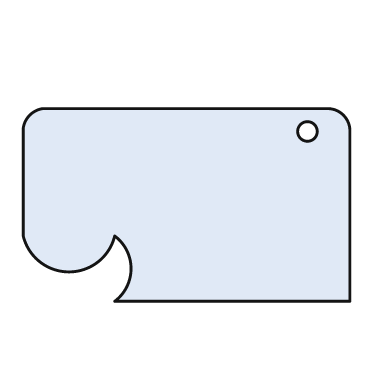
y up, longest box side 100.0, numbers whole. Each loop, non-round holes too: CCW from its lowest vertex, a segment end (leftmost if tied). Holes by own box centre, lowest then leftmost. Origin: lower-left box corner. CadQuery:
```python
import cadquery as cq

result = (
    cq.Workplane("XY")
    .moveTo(28.0, 0.0)
    .lineTo(100.0, 0.0)
    .lineTo(100.0, 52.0)
    .threePointArc((98.0, 57.0), (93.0, 59.0))
    .lineTo(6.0, 59.0)
    .threePointArc((2.0, 57.0), (0.0, 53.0))
    .lineTo(0.0, 20.0)
    .threePointArc((14.0, 9.0), (28.0, 20.0))
    .threePointArc((33.0, 10.0), (28.0, 0.0))
    .close()
    .moveTo(87.0, 52.0)
    .circle(3.0)
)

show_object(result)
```